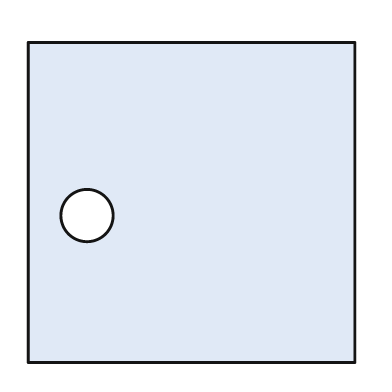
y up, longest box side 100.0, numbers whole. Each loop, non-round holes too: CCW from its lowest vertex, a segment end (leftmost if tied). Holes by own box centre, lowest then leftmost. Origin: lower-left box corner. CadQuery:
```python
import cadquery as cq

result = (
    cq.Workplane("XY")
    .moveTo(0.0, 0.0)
    .lineTo(100.0, 0.0)
    .lineTo(100.0, 98.0)
    .lineTo(0.0, 98.0)
    .close()
    .moveTo(18.0, 45.0)
    .circle(8.0)
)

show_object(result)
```